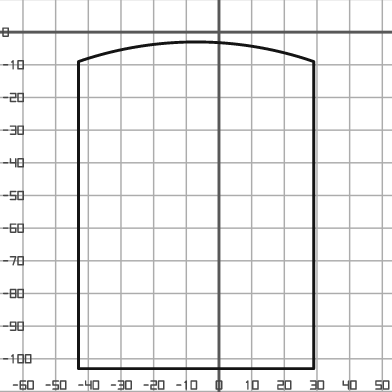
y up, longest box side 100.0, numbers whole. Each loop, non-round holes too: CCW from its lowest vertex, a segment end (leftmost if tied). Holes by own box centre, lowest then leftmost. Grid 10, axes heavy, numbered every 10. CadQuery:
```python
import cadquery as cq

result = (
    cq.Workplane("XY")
    .moveTo(-43.0, -103.0)
    .lineTo(29.0, -103.0)
    .lineTo(29.0, -9.0)
    .threePointArc((-7.0, -3.0), (-43.0, -9.0))
    .close()
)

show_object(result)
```